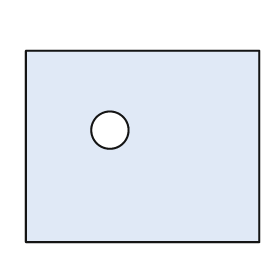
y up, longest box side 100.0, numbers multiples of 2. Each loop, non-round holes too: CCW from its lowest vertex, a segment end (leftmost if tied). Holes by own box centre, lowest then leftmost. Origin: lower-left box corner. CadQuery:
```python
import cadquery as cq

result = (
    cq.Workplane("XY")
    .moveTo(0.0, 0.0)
    .lineTo(100.0, 0.0)
    .lineTo(100.0, 82.0)
    .lineTo(0.0, 82.0)
    .close()
    .moveTo(36.0, 48.0)
    .circle(8.0)
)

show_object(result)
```